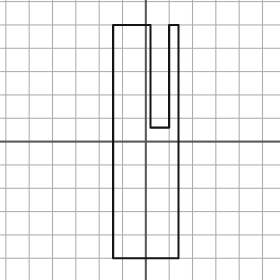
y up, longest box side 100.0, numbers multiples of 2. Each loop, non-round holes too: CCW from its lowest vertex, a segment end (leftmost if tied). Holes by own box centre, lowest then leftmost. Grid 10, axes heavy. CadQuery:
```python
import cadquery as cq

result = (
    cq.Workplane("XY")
    .moveTo(-14.0, -50.0)
    .lineTo(14.0, -50.0)
    .lineTo(14.0, 50.0)
    .lineTo(10.0, 50.0)
    .lineTo(10.0, 6.0)
    .lineTo(2.0, 6.0)
    .lineTo(2.0, 50.0)
    .lineTo(-14.0, 50.0)
    .close()
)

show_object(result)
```